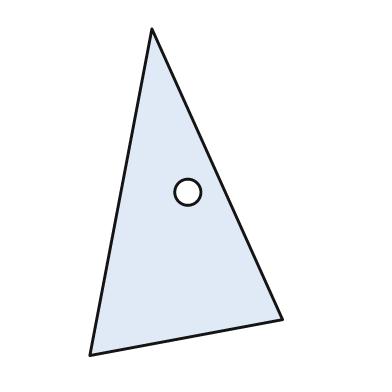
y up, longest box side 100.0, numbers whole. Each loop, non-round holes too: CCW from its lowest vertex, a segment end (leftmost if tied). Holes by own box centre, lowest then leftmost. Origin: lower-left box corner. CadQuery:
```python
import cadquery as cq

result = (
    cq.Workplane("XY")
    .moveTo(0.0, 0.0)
    .lineTo(59.0, 11.0)
    .lineTo(19.0, 100.0)
    .close()
    .moveTo(30.0, 50.0)
    .circle(4.0)
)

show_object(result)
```